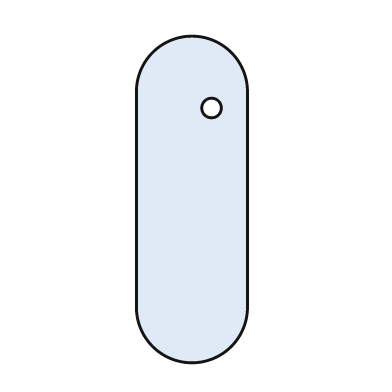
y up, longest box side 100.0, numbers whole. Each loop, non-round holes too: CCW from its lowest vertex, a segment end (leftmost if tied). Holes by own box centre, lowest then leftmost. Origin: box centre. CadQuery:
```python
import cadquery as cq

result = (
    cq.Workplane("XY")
    .moveTo(-17.0, -33.0)
    .threePointArc((0.0, -50.0), (17.0, -33.0))
    .lineTo(17.0, 33.0)
    .threePointArc((0.0, 50.0), (-17.0, 33.0))
    .close()
    .moveTo(6.0, 28.0)
    .circle(3.0)
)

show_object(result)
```